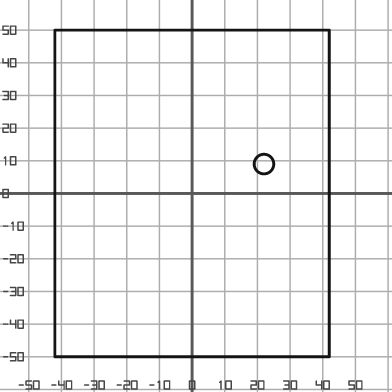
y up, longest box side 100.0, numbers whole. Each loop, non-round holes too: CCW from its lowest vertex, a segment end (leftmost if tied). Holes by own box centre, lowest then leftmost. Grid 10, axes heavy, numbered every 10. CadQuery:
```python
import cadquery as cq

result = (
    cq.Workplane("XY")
    .moveTo(-42.0, -50.0)
    .lineTo(42.0, -50.0)
    .lineTo(42.0, 50.0)
    .lineTo(-42.0, 50.0)
    .close()
    .moveTo(22.0, 9.0)
    .circle(3.0)
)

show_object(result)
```